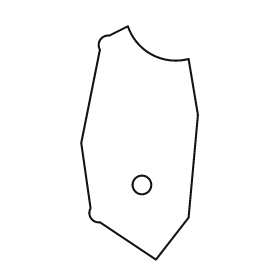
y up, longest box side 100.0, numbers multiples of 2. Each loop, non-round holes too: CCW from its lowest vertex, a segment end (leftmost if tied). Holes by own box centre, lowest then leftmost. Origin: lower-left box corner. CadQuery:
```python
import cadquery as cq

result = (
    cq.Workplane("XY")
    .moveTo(32.0, 0.0)
    .lineTo(46.0, 18.0)
    .lineTo(50.0, 62.0)
    .lineTo(46.0, 86.0)
    .threePointArc((30.0, 88.0), (20.0, 100.0))
    .lineTo(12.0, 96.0)
    .threePointArc((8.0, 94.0), (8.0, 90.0))
    .lineTo(0.0, 50.0)
    .lineTo(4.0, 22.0)
    .threePointArc((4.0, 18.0), (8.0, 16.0))
    .close()
    .moveTo(26.0, 32.0)
    .circle(4.0)
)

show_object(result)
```